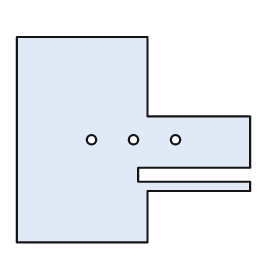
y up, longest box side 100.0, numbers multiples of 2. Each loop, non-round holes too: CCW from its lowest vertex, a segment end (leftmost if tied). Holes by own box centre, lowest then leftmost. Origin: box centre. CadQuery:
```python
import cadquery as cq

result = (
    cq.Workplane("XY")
    .moveTo(-50.0, -44.0)
    .lineTo(6.0, -44.0)
    .lineTo(6.0, -22.0)
    .lineTo(50.0, -22.0)
    .lineTo(50.0, -18.0)
    .lineTo(2.0, -18.0)
    .lineTo(2.0, -12.0)
    .lineTo(50.0, -12.0)
    .lineTo(50.0, 10.0)
    .lineTo(6.0, 10.0)
    .lineTo(6.0, 44.0)
    .lineTo(-50.0, 44.0)
    .close()
    .moveTo(-18.0, 0.0)
    .circle(2.0)
    .moveTo(0.0, 0.0)
    .circle(2.0)
    .moveTo(18.0, 0.0)
    .circle(2.0)
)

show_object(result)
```